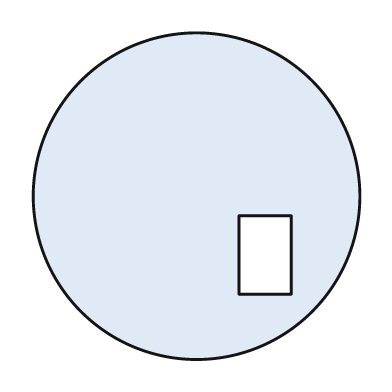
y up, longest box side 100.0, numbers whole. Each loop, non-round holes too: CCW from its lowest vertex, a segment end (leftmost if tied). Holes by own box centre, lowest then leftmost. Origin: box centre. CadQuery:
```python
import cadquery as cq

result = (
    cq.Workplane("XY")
    .moveTo(0.0, 0.0)
    .circle(50.0)
    .moveTo(13.0, -30.0)
    .lineTo(29.0, -30.0)
    .lineTo(29.0, -6.0)
    .lineTo(13.0, -6.0)
    .close()
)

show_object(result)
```